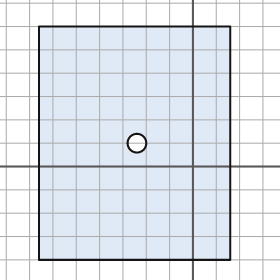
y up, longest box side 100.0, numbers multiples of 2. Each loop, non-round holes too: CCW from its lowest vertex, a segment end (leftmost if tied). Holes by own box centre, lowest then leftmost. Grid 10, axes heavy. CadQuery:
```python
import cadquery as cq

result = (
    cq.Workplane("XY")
    .moveTo(-66.0, -40.0)
    .lineTo(16.0, -40.0)
    .lineTo(16.0, 60.0)
    .lineTo(-66.0, 60.0)
    .close()
    .moveTo(-24.0, 10.0)
    .circle(4.0)
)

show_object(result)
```